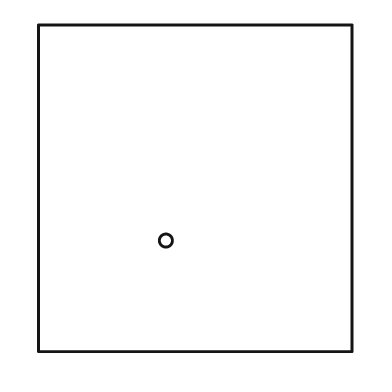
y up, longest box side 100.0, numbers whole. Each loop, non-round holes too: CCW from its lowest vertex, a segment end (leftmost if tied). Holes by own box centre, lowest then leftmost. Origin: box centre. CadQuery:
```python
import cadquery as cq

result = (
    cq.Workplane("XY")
    .moveTo(-48.0, -50.0)
    .lineTo(48.0, -50.0)
    .lineTo(48.0, 50.0)
    .lineTo(-48.0, 50.0)
    .close()
    .moveTo(-9.0, -16.0)
    .circle(2.0)
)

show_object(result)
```